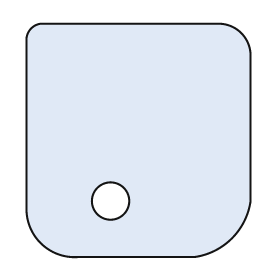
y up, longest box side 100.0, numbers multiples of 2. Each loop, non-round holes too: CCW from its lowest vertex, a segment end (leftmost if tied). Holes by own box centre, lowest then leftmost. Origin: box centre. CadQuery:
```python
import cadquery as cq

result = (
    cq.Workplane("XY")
    .moveTo(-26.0, -50.0)
    .lineTo(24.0, -50.0)
    .threePointArc((40.0, -42.0), (48.0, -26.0))
    .lineTo(48.0, 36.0)
    .threePointArc((44.0, 46.0), (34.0, 50.0))
    .lineTo(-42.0, 50.0)
    .threePointArc((-46.0, 48.0), (-48.0, 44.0))
    .lineTo(-48.0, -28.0)
    .threePointArc((-42.0, -44.0), (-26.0, -50.0))
    .close()
    .moveTo(-12.0, -26.0)
    .circle(8.0)
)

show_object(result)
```